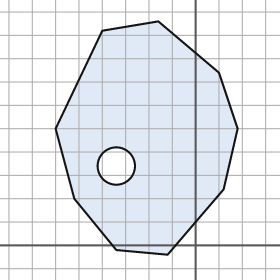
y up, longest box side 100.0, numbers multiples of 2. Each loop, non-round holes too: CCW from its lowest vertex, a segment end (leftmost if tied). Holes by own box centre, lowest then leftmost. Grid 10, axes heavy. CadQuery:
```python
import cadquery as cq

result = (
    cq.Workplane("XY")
    .moveTo(-12.0, -4.0)
    .lineTo(12.0, 24.0)
    .lineTo(18.0, 50.0)
    .lineTo(10.0, 74.0)
    .lineTo(-16.0, 96.0)
    .lineTo(-40.0, 92.0)
    .lineTo(-60.0, 50.0)
    .lineTo(-52.0, 20.0)
    .lineTo(-34.0, -2.0)
    .close()
    .moveTo(-34.0, 34.0)
    .circle(8.0)
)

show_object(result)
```